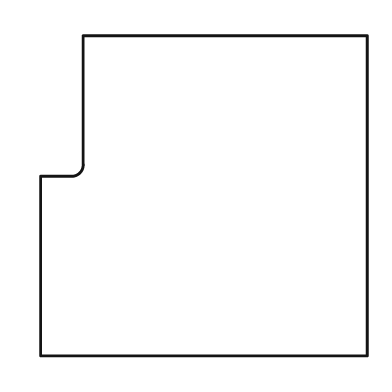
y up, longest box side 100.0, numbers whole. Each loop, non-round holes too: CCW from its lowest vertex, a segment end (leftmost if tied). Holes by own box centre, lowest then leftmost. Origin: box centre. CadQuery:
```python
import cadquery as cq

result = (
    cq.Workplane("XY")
    .moveTo(-50.0, -49.0)
    .lineTo(50.0, -49.0)
    .lineTo(50.0, 49.0)
    .lineTo(-37.0, 49.0)
    .lineTo(-37.0, 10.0)
    .threePointArc((-38.0, 7.0), (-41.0, 6.0))
    .lineTo(-50.0, 6.0)
    .close()
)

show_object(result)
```